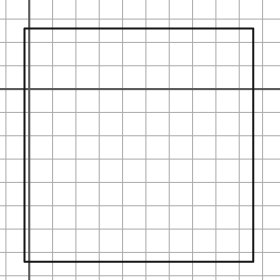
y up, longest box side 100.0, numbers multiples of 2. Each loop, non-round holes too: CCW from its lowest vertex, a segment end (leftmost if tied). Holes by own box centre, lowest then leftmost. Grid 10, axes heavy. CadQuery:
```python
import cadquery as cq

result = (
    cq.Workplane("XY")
    .moveTo(-2.0, -74.0)
    .lineTo(96.0, -74.0)
    .lineTo(96.0, 26.0)
    .lineTo(-2.0, 26.0)
    .close()
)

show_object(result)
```